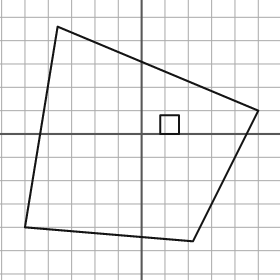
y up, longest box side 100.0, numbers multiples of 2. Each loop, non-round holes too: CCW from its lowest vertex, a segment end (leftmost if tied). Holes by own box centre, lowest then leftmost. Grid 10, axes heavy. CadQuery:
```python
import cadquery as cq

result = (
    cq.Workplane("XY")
    .moveTo(22.0, -46.0)
    .lineTo(50.0, 10.0)
    .lineTo(-36.0, 46.0)
    .lineTo(-50.0, -40.0)
    .close()
    .moveTo(8.0, 0.0)
    .lineTo(16.0, 0.0)
    .lineTo(16.0, 8.0)
    .lineTo(8.0, 8.0)
    .close()
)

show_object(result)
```